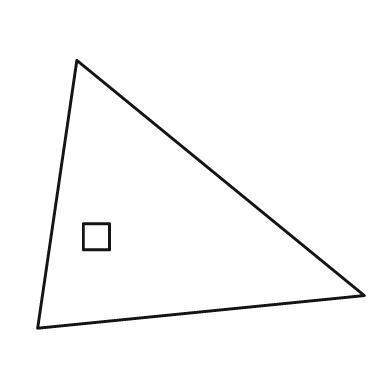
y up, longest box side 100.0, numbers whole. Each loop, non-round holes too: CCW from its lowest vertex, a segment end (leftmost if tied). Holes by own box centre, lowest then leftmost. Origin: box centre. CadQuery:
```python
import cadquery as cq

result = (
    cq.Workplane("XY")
    .moveTo(-50.0, -41.0)
    .lineTo(50.0, -31.0)
    .lineTo(-38.0, 41.0)
    .close()
    .moveTo(-36.0, -17.0)
    .lineTo(-28.0, -17.0)
    .lineTo(-28.0, -9.0)
    .lineTo(-36.0, -9.0)
    .close()
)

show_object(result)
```